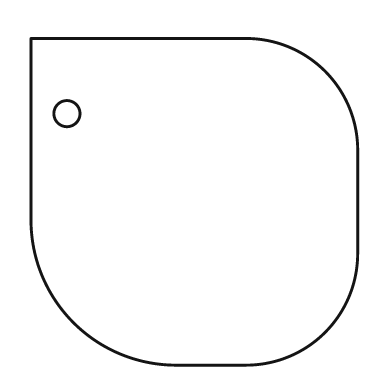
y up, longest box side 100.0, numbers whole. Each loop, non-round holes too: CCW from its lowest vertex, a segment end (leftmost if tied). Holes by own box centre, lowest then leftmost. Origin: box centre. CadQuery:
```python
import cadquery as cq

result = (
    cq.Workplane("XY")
    .moveTo(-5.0, -50.0)
    .lineTo(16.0, -50.0)
    .threePointArc((40.0, -40.0), (50.0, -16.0))
    .lineTo(50.0, 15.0)
    .threePointArc((40.0, 40.0), (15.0, 50.0))
    .lineTo(-50.0, 50.0)
    .lineTo(-50.0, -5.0)
    .threePointArc((-37.0, -37.0), (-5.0, -50.0))
    .close()
    .moveTo(-39.0, 27.0)
    .circle(4.0)
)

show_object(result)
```